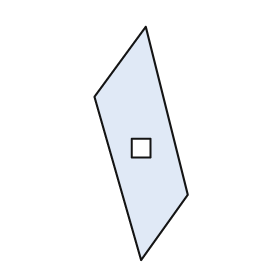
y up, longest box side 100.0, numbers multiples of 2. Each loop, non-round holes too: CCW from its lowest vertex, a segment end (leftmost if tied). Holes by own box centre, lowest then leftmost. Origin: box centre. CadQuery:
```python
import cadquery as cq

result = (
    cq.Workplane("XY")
    .moveTo(0.0, -50.0)
    .lineTo(20.0, -22.0)
    .lineTo(2.0, 50.0)
    .lineTo(-20.0, 20.0)
    .close()
    .moveTo(-4.0, -6.0)
    .lineTo(4.0, -6.0)
    .lineTo(4.0, 2.0)
    .lineTo(-4.0, 2.0)
    .close()
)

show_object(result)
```